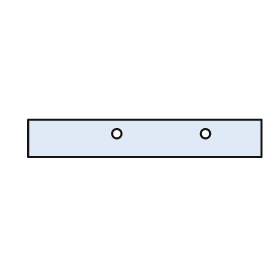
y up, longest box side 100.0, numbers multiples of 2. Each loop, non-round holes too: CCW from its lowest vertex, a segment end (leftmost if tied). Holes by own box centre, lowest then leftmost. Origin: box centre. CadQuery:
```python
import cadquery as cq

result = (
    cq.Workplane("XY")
    .moveTo(-50.0, -8.0)
    .lineTo(50.0, -8.0)
    .lineTo(50.0, 8.0)
    .lineTo(-50.0, 8.0)
    .close()
    .moveTo(-12.0, 2.0)
    .circle(2.0)
    .moveTo(26.0, 2.0)
    .circle(2.0)
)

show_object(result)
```